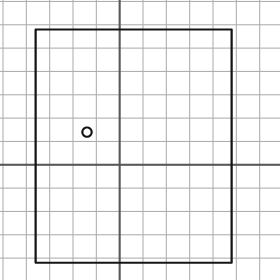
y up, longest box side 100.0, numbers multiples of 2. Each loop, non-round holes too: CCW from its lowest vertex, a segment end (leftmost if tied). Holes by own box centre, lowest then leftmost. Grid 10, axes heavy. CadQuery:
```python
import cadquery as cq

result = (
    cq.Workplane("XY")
    .moveTo(-36.0, -42.0)
    .lineTo(48.0, -42.0)
    .lineTo(48.0, 58.0)
    .lineTo(-36.0, 58.0)
    .close()
    .moveTo(-14.0, 14.0)
    .circle(2.0)
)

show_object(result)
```